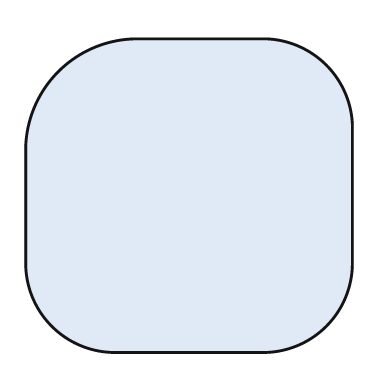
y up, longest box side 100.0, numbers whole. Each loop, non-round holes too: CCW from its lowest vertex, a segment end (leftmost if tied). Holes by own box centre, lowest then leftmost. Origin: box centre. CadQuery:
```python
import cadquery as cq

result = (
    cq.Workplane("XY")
    .moveTo(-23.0, -48.0)
    .lineTo(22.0, -48.0)
    .threePointArc((42.0, -40.0), (50.0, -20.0))
    .lineTo(50.0, 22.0)
    .threePointArc((42.0, 40.0), (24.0, 48.0))
    .lineTo(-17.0, 48.0)
    .threePointArc((-40.0, 38.0), (-50.0, 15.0))
    .lineTo(-50.0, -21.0)
    .threePointArc((-42.0, -40.0), (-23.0, -48.0))
    .close()
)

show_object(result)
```